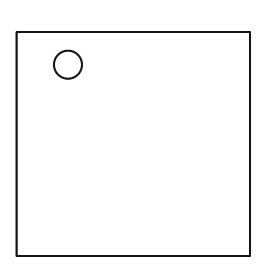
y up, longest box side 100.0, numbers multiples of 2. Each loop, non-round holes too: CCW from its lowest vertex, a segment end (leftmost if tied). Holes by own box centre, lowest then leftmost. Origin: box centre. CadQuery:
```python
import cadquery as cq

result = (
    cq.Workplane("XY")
    .moveTo(-50.0, -48.0)
    .lineTo(50.0, -48.0)
    .lineTo(50.0, 48.0)
    .lineTo(-50.0, 48.0)
    .close()
    .moveTo(-28.0, 34.0)
    .circle(6.0)
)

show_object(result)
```